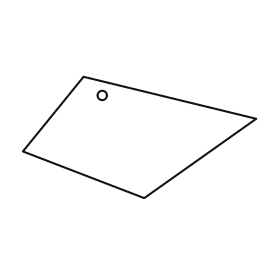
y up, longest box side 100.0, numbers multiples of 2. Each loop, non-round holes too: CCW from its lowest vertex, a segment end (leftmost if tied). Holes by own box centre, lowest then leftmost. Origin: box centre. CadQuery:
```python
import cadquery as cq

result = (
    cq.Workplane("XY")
    .moveTo(2.0, -26.0)
    .lineTo(50.0, 8.0)
    .lineTo(-24.0, 26.0)
    .lineTo(-50.0, -6.0)
    .close()
    .moveTo(-16.0, 18.0)
    .circle(2.0)
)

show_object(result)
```